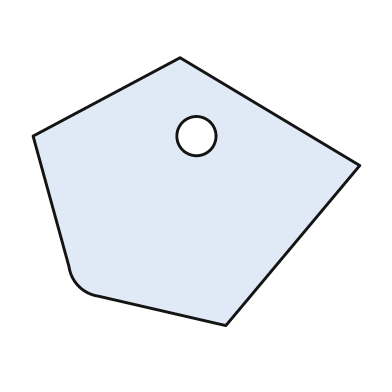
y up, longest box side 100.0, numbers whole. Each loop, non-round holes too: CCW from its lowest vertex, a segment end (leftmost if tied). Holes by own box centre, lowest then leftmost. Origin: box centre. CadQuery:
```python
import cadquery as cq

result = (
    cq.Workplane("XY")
    .moveTo(9.0, -41.0)
    .lineTo(50.0, 8.0)
    .lineTo(-5.0, 41.0)
    .lineTo(-50.0, 17.0)
    .lineTo(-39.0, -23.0)
    .threePointArc((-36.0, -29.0), (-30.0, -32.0))
    .close()
    .moveTo(0.0, 17.0)
    .circle(6.0)
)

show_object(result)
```